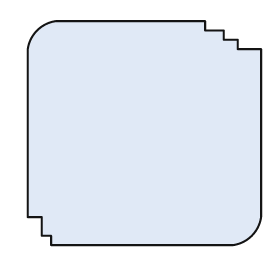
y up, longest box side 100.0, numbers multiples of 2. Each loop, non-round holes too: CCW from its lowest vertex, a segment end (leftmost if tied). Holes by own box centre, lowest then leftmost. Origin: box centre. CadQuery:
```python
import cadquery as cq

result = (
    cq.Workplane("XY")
    .moveTo(-40.0, -48.0)
    .lineTo(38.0, -48.0)
    .threePointArc((46.0, -44.0), (50.0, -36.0))
    .lineTo(50.0, 36.0)
    .lineTo(40.0, 36.0)
    .lineTo(40.0, 40.0)
    .lineTo(34.0, 40.0)
    .lineTo(34.0, 44.0)
    .lineTo(26.0, 44.0)
    .lineTo(26.0, 48.0)
    .lineTo(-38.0, 48.0)
    .threePointArc((-46.0, 44.0), (-50.0, 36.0))
    .lineTo(-50.0, -36.0)
    .lineTo(-44.0, -36.0)
    .lineTo(-44.0, -44.0)
    .lineTo(-40.0, -44.0)
    .close()
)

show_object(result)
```